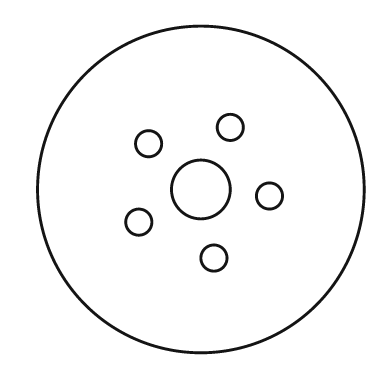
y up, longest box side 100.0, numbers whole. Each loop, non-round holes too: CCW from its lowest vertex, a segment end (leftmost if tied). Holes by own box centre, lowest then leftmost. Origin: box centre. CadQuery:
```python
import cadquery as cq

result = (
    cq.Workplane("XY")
    .moveTo(0.0, 0.0)
    .circle(50.0)
    .moveTo(4.0, -21.0)
    .circle(4.0)
    .moveTo(-19.0, -10.0)
    .circle(4.0)
    .moveTo(21.0, -2.0)
    .circle(4.0)
    .moveTo(0.0, 0.0)
    .circle(9.0)
    .moveTo(-16.0, 14.0)
    .circle(4.0)
    .moveTo(9.0, 19.0)
    .circle(4.0)
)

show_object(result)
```